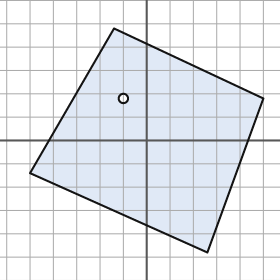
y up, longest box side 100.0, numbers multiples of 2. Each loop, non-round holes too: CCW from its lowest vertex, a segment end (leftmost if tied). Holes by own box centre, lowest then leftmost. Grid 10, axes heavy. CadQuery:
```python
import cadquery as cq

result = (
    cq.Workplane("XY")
    .moveTo(26.0, -48.0)
    .lineTo(50.0, 18.0)
    .lineTo(-14.0, 48.0)
    .lineTo(-50.0, -14.0)
    .close()
    .moveTo(-10.0, 18.0)
    .circle(2.0)
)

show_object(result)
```